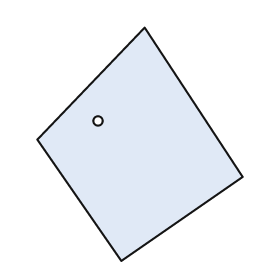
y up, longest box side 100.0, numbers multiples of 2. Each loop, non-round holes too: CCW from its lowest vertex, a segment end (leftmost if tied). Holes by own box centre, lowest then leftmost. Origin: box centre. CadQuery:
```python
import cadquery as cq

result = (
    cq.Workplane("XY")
    .moveTo(-8.0, -50.0)
    .lineTo(44.0, -14.0)
    .lineTo(2.0, 50.0)
    .lineTo(-44.0, 2.0)
    .close()
    .moveTo(-18.0, 10.0)
    .circle(2.0)
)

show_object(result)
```